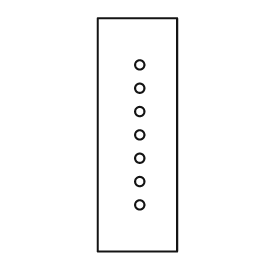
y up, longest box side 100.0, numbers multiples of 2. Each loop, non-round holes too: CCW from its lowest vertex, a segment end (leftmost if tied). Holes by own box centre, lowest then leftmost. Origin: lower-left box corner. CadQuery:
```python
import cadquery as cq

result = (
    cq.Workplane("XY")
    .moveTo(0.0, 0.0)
    .lineTo(34.0, 0.0)
    .lineTo(34.0, 100.0)
    .lineTo(0.0, 100.0)
    .close()
    .moveTo(18.0, 20.0)
    .circle(2.0)
    .moveTo(18.0, 30.0)
    .circle(2.0)
    .moveTo(18.0, 40.0)
    .circle(2.0)
    .moveTo(18.0, 50.0)
    .circle(2.0)
    .moveTo(18.0, 60.0)
    .circle(2.0)
    .moveTo(18.0, 70.0)
    .circle(2.0)
    .moveTo(18.0, 80.0)
    .circle(2.0)
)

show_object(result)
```